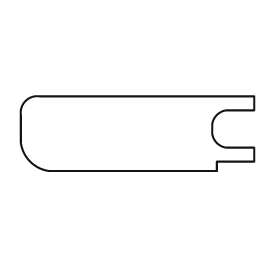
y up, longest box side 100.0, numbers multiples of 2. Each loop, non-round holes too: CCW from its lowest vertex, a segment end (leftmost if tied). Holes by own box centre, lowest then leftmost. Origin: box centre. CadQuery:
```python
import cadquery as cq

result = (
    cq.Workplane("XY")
    .moveTo(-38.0, -16.0)
    .lineTo(34.0, -16.0)
    .lineTo(34.0, -12.0)
    .lineTo(50.0, -12.0)
    .lineTo(50.0, -6.0)
    .lineTo(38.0, -6.0)
    .threePointArc((34.0, -4.0), (32.0, 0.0))
    .lineTo(32.0, 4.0)
    .threePointArc((34.0, 8.0), (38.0, 10.0))
    .lineTo(50.0, 10.0)
    .lineTo(50.0, 16.0)
    .lineTo(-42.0, 16.0)
    .threePointArc((-48.0, 14.0), (-50.0, 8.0))
    .lineTo(-50.0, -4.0)
    .threePointArc((-46.0, -12.0), (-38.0, -16.0))
    .close()
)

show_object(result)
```